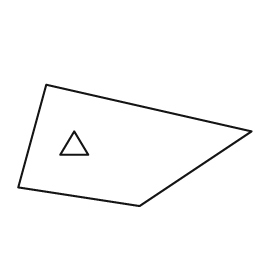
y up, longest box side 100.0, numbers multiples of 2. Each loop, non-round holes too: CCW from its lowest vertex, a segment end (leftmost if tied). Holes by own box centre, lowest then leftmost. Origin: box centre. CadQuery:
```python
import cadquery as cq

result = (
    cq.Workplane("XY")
    .moveTo(2.0, -26.0)
    .lineTo(50.0, 6.0)
    .lineTo(-38.0, 26.0)
    .lineTo(-50.0, -18.0)
    .close()
    .moveTo(-32.0, -4.0)
    .lineTo(-20.0, -4.0)
    .lineTo(-26.0, 6.0)
    .close()
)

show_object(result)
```